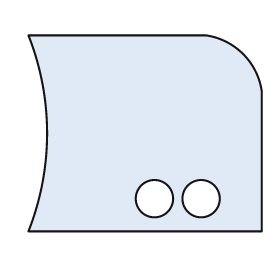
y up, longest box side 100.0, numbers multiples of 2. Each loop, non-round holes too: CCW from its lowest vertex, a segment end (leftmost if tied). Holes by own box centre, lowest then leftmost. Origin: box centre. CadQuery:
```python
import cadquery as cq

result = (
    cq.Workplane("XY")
    .moveTo(-50.0, -42.0)
    .lineTo(50.0, -42.0)
    .lineTo(50.0, 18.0)
    .threePointArc((42.0, 34.0), (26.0, 42.0))
    .lineTo(-50.0, 42.0)
    .threePointArc((-42.0, 0.0), (-50.0, -42.0))
    .close()
    .moveTo(4.0, -28.0)
    .circle(8.0)
    .moveTo(24.0, -28.0)
    .circle(8.0)
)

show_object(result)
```